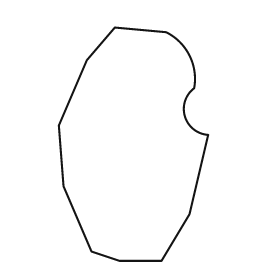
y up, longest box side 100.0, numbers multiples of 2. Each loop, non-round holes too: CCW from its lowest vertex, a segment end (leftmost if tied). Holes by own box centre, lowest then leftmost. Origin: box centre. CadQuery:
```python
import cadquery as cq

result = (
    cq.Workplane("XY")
    .moveTo(-6.0, -50.0)
    .lineTo(12.0, -50.0)
    .lineTo(24.0, -30.0)
    .lineTo(32.0, 4.0)
    .threePointArc((22.0, 12.0), (26.0, 24.0))
    .threePointArc((24.0, 38.0), (14.0, 48.0))
    .lineTo(-8.0, 50.0)
    .lineTo(-20.0, 36.0)
    .lineTo(-32.0, 8.0)
    .lineTo(-30.0, -18.0)
    .lineTo(-18.0, -46.0)
    .close()
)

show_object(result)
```